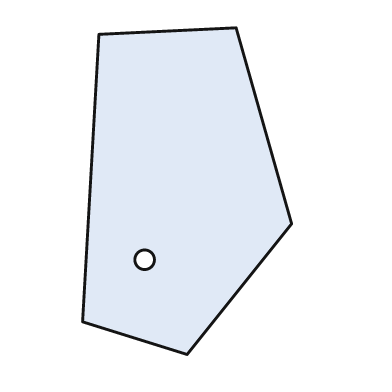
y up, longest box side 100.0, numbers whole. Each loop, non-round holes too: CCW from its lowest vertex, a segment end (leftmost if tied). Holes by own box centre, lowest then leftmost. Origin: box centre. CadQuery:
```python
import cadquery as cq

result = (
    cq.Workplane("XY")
    .moveTo(0.0, -50.0)
    .lineTo(32.0, -10.0)
    .lineTo(15.0, 50.0)
    .lineTo(-27.0, 48.0)
    .lineTo(-32.0, -40.0)
    .close()
    .moveTo(-13.0, -21.0)
    .circle(3.0)
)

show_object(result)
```